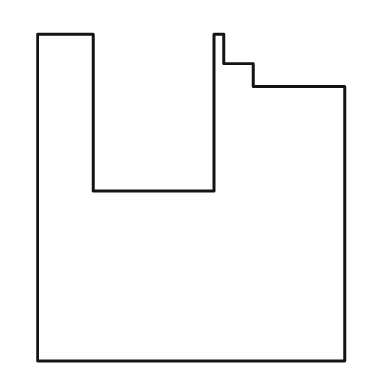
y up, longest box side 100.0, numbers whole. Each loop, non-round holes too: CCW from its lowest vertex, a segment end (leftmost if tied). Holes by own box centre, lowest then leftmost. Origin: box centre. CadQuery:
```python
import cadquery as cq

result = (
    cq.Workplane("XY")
    .moveTo(-47.0, -50.0)
    .lineTo(47.0, -50.0)
    .lineTo(47.0, 34.0)
    .lineTo(19.0, 34.0)
    .lineTo(19.0, 41.0)
    .lineTo(10.0, 41.0)
    .lineTo(10.0, 50.0)
    .lineTo(7.0, 50.0)
    .lineTo(7.0, 2.0)
    .lineTo(-30.0, 2.0)
    .lineTo(-30.0, 50.0)
    .lineTo(-47.0, 50.0)
    .close()
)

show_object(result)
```